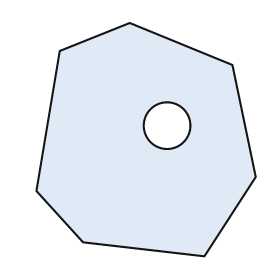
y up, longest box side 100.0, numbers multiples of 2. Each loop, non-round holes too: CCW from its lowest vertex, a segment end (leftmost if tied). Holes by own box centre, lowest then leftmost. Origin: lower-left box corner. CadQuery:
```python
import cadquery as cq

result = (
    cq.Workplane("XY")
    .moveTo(72.0, 0.0)
    .lineTo(94.0, 34.0)
    .lineTo(84.0, 82.0)
    .lineTo(40.0, 100.0)
    .lineTo(10.0, 88.0)
    .lineTo(0.0, 28.0)
    .lineTo(20.0, 6.0)
    .close()
    .moveTo(56.0, 56.0)
    .circle(10.0)
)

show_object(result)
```